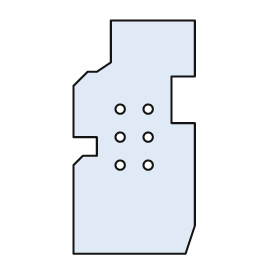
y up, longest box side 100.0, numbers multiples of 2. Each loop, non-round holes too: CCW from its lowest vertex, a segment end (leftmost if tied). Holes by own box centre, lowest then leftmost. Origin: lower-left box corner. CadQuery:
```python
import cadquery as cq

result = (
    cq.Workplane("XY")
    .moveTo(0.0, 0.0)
    .lineTo(48.0, 0.0)
    .lineTo(52.0, 12.0)
    .lineTo(52.0, 56.0)
    .lineTo(42.0, 56.0)
    .lineTo(42.0, 76.0)
    .lineTo(52.0, 76.0)
    .lineTo(52.0, 100.0)
    .lineTo(16.0, 100.0)
    .lineTo(16.0, 82.0)
    .lineTo(10.0, 78.0)
    .lineTo(6.0, 78.0)
    .lineTo(0.0, 72.0)
    .lineTo(0.0, 50.0)
    .lineTo(10.0, 50.0)
    .lineTo(10.0, 42.0)
    .lineTo(4.0, 42.0)
    .lineTo(0.0, 38.0)
    .close()
    .moveTo(20.0, 38.0)
    .circle(2.0)
    .moveTo(32.0, 38.0)
    .circle(2.0)
    .moveTo(20.0, 50.0)
    .circle(2.0)
    .moveTo(32.0, 50.0)
    .circle(2.0)
    .moveTo(20.0, 62.0)
    .circle(2.0)
    .moveTo(32.0, 62.0)
    .circle(2.0)
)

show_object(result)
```